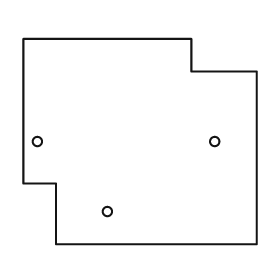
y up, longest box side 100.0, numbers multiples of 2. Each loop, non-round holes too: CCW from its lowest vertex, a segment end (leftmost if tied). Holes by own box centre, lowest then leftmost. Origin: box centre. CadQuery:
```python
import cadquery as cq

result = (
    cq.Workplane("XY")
    .moveTo(-36.0, -44.0)
    .lineTo(50.0, -44.0)
    .lineTo(50.0, 30.0)
    .lineTo(22.0, 30.0)
    .lineTo(22.0, 44.0)
    .lineTo(-50.0, 44.0)
    .lineTo(-50.0, -18.0)
    .lineTo(-36.0, -18.0)
    .close()
    .moveTo(-14.0, -30.0)
    .circle(2.0)
    .moveTo(-44.0, 0.0)
    .circle(2.0)
    .moveTo(32.0, 0.0)
    .circle(2.0)
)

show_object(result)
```